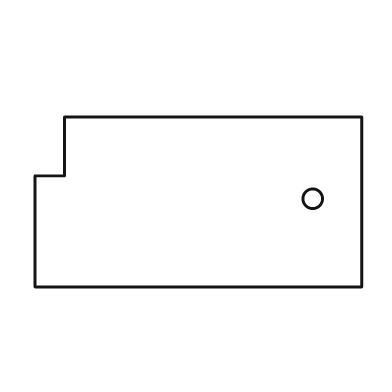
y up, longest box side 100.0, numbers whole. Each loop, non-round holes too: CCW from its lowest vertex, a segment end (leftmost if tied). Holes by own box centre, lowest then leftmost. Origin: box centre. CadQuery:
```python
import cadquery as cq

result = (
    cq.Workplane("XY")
    .moveTo(-50.0, -26.0)
    .lineTo(50.0, -26.0)
    .lineTo(50.0, 26.0)
    .lineTo(-41.0, 26.0)
    .lineTo(-41.0, 8.0)
    .lineTo(-50.0, 8.0)
    .close()
    .moveTo(35.0, 1.0)
    .circle(3.0)
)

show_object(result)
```